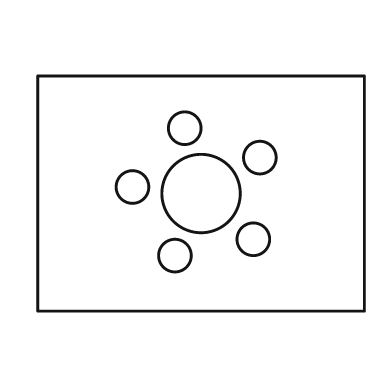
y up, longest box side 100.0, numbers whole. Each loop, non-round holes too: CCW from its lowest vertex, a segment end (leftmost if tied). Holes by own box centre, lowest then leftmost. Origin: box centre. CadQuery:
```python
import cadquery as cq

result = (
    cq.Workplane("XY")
    .moveTo(-50.0, -36.0)
    .lineTo(50.0, -36.0)
    .lineTo(50.0, 36.0)
    .lineTo(-50.0, 36.0)
    .close()
    .moveTo(-8.0, -19.0)
    .circle(5.0)
    .moveTo(16.0, -14.0)
    .circle(5.0)
    .moveTo(0.0, 0.0)
    .circle(12.0)
    .moveTo(-21.0, 2.0)
    .circle(5.0)
    .moveTo(18.0, 11.0)
    .circle(5.0)
    .moveTo(-5.0, 20.0)
    .circle(5.0)
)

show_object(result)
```